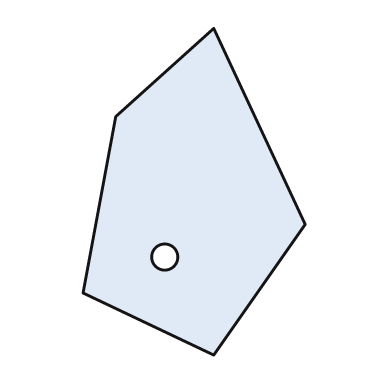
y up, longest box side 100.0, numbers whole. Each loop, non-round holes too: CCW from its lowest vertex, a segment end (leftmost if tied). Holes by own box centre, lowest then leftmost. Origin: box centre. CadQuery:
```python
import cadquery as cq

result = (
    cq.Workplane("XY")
    .moveTo(6.0, -50.0)
    .lineTo(34.0, -10.0)
    .lineTo(6.0, 50.0)
    .lineTo(-24.0, 23.0)
    .lineTo(-34.0, -31.0)
    .close()
    .moveTo(-9.0, -20.0)
    .circle(4.0)
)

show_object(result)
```